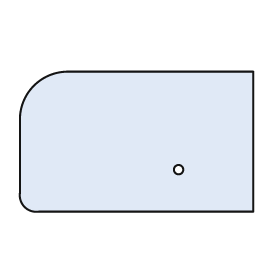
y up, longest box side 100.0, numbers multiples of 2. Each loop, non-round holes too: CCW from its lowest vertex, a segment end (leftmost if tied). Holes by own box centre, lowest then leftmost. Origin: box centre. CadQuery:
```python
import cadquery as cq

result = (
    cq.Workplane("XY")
    .moveTo(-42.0, -30.0)
    .lineTo(50.0, -30.0)
    .lineTo(50.0, 30.0)
    .lineTo(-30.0, 30.0)
    .threePointArc((-44.0, 24.0), (-50.0, 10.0))
    .lineTo(-50.0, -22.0)
    .threePointArc((-48.0, -28.0), (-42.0, -30.0))
    .close()
    .moveTo(18.0, -12.0)
    .circle(2.0)
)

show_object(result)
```